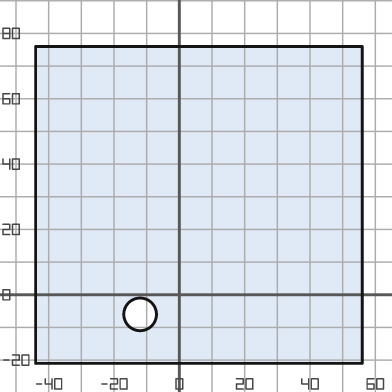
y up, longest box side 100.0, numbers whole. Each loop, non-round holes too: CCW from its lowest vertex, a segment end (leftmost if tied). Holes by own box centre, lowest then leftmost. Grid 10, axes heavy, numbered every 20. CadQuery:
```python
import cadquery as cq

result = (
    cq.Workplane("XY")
    .moveTo(-44.0, -21.0)
    .lineTo(56.0, -21.0)
    .lineTo(56.0, 76.0)
    .lineTo(-44.0, 76.0)
    .close()
    .moveTo(-12.0, -6.0)
    .circle(5.0)
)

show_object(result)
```